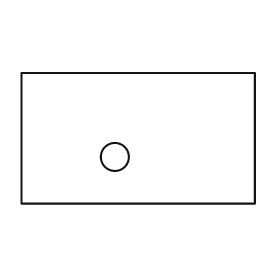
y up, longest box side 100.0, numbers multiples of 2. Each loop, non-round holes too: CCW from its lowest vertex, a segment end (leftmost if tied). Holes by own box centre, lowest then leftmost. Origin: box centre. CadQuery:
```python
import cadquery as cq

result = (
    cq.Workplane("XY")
    .moveTo(-50.0, -28.0)
    .lineTo(50.0, -28.0)
    .lineTo(50.0, 28.0)
    .lineTo(-50.0, 28.0)
    .close()
    .moveTo(-10.0, -8.0)
    .circle(6.0)
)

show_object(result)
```